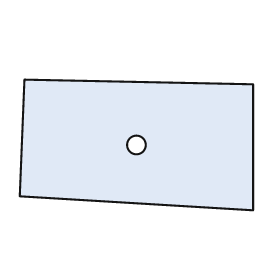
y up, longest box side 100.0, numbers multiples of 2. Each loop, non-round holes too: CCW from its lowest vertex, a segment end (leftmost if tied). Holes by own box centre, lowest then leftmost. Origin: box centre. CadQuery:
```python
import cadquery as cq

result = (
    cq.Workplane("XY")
    .moveTo(50.0, -28.0)
    .lineTo(50.0, 26.0)
    .lineTo(-48.0, 28.0)
    .lineTo(-50.0, -22.0)
    .close()
    .moveTo(0.0, 0.0)
    .circle(4.0)
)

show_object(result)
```